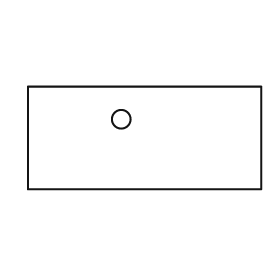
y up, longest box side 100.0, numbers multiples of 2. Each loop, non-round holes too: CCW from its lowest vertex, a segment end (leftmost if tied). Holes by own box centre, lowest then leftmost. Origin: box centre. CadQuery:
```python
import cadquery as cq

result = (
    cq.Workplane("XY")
    .moveTo(-50.0, -22.0)
    .lineTo(50.0, -22.0)
    .lineTo(50.0, 22.0)
    .lineTo(-50.0, 22.0)
    .close()
    .moveTo(-10.0, 8.0)
    .circle(4.0)
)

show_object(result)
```